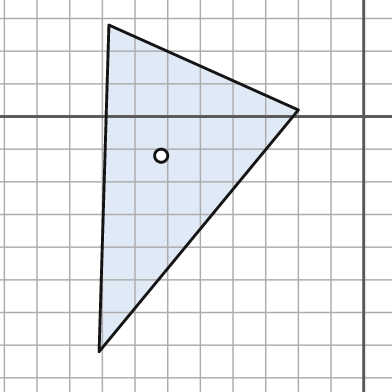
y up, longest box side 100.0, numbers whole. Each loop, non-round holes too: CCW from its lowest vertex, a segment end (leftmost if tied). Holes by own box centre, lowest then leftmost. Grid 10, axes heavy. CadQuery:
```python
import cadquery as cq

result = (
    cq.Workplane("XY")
    .moveTo(-81.0, -72.0)
    .lineTo(-20.0, 2.0)
    .lineTo(-78.0, 28.0)
    .close()
    .moveTo(-62.0, -12.0)
    .circle(2.0)
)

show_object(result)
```